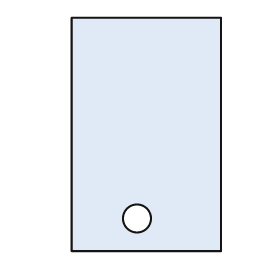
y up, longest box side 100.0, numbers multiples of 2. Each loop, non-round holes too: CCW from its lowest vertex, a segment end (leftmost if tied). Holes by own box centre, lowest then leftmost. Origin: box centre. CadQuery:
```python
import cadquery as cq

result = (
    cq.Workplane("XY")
    .moveTo(-32.0, -50.0)
    .lineTo(32.0, -50.0)
    .lineTo(32.0, 50.0)
    .lineTo(-32.0, 50.0)
    .close()
    .moveTo(-4.0, -36.0)
    .circle(6.0)
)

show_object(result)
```